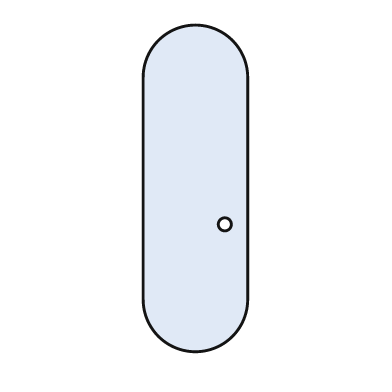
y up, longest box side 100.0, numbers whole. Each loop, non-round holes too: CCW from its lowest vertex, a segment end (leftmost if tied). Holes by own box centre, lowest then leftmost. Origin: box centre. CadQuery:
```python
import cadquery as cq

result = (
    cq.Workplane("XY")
    .moveTo(-16.0, -34.0)
    .threePointArc((0.0, -50.0), (16.0, -34.0))
    .lineTo(16.0, 34.0)
    .threePointArc((0.0, 50.0), (-16.0, 34.0))
    .close()
    .moveTo(9.0, -11.0)
    .circle(2.0)
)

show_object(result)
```